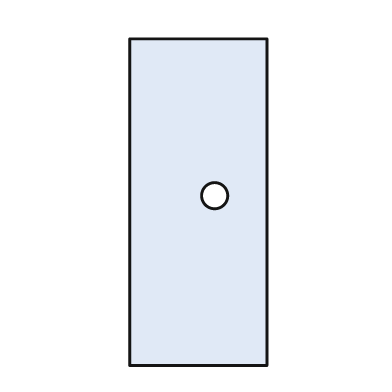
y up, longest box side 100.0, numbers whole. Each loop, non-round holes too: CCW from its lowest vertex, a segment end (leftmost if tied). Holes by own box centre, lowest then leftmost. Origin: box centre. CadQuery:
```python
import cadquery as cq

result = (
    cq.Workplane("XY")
    .moveTo(-21.0, -50.0)
    .lineTo(21.0, -50.0)
    .lineTo(21.0, 50.0)
    .lineTo(-21.0, 50.0)
    .close()
    .moveTo(5.0, 2.0)
    .circle(4.0)
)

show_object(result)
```